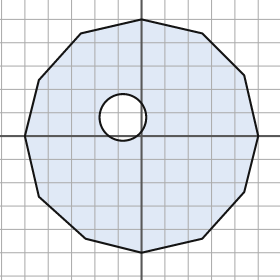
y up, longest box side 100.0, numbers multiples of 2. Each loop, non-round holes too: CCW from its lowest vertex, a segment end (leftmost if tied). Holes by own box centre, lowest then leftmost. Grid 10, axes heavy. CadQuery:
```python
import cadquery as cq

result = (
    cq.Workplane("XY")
    .moveTo(0.0, -50.0)
    .lineTo(26.0, -44.0)
    .lineTo(44.0, -24.0)
    .lineTo(50.0, 0.0)
    .lineTo(44.0, 26.0)
    .lineTo(26.0, 44.0)
    .lineTo(0.0, 50.0)
    .lineTo(-26.0, 44.0)
    .lineTo(-44.0, 24.0)
    .lineTo(-50.0, 0.0)
    .lineTo(-44.0, -26.0)
    .lineTo(-24.0, -44.0)
    .close()
    .moveTo(-8.0, 8.0)
    .circle(10.0)
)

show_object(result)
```